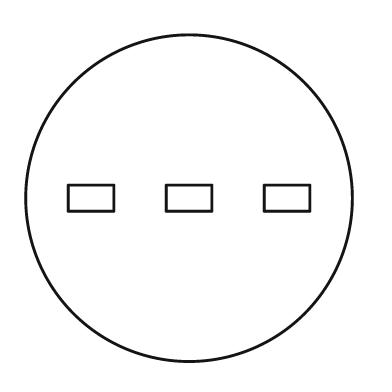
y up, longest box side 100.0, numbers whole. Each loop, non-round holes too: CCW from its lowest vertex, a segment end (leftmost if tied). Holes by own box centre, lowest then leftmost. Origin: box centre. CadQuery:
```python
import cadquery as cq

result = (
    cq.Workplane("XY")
    .moveTo(0.0, 0.0)
    .circle(50.0)
    .moveTo(-37.0, -4.0)
    .lineTo(-23.0, -4.0)
    .lineTo(-23.0, 4.0)
    .lineTo(-37.0, 4.0)
    .close()
    .moveTo(-7.0, -4.0)
    .lineTo(7.0, -4.0)
    .lineTo(7.0, 4.0)
    .lineTo(-7.0, 4.0)
    .close()
    .moveTo(23.0, -4.0)
    .lineTo(37.0, -4.0)
    .lineTo(37.0, 4.0)
    .lineTo(23.0, 4.0)
    .close()
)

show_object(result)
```